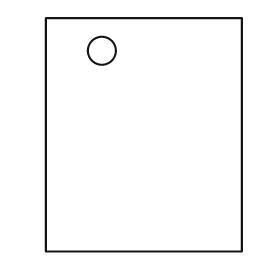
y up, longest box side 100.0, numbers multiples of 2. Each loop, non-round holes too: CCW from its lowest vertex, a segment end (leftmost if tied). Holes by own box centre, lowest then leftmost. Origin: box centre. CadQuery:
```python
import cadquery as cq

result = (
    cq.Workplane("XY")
    .moveTo(-42.0, -50.0)
    .lineTo(42.0, -50.0)
    .lineTo(42.0, 50.0)
    .lineTo(-42.0, 50.0)
    .close()
    .moveTo(-18.0, 36.0)
    .circle(6.0)
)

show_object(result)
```